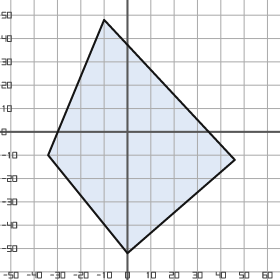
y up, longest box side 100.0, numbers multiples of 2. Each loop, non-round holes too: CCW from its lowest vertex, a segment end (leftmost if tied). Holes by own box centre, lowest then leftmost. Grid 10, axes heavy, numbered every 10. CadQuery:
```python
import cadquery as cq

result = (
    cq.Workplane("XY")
    .moveTo(0.0, -52.0)
    .lineTo(46.0, -12.0)
    .lineTo(-10.0, 48.0)
    .lineTo(-34.0, -10.0)
    .close()
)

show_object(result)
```